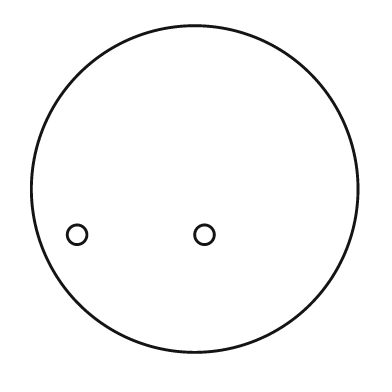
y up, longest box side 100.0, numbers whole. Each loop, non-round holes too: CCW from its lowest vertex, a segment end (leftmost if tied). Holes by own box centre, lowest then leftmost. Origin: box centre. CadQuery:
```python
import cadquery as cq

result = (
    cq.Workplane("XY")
    .moveTo(0.0, 0.0)
    .circle(50.0)
    .moveTo(-36.0, -14.0)
    .circle(3.0)
    .moveTo(3.0, -14.0)
    .circle(3.0)
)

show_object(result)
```